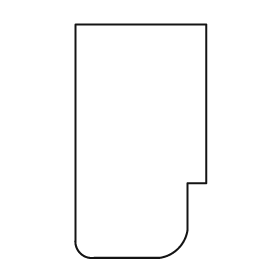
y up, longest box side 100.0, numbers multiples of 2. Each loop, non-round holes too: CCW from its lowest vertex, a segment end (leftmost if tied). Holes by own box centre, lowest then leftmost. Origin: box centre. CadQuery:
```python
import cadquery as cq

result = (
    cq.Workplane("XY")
    .moveTo(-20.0, -50.0)
    .lineTo(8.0, -50.0)
    .threePointArc((16.0, -46.0), (20.0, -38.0))
    .lineTo(20.0, -18.0)
    .lineTo(28.0, -18.0)
    .lineTo(28.0, 50.0)
    .lineTo(-28.0, 50.0)
    .lineTo(-28.0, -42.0)
    .threePointArc((-26.0, -48.0), (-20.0, -50.0))
    .close()
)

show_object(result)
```